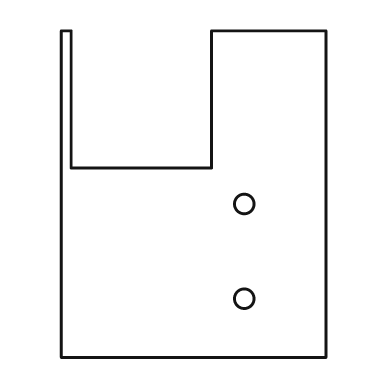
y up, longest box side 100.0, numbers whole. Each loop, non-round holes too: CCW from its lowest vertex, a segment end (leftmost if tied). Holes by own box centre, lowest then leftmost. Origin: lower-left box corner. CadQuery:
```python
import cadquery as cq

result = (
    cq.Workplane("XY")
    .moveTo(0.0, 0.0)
    .lineTo(81.0, 0.0)
    .lineTo(81.0, 100.0)
    .lineTo(46.0, 100.0)
    .lineTo(46.0, 58.0)
    .lineTo(3.0, 58.0)
    .lineTo(3.0, 100.0)
    .lineTo(0.0, 100.0)
    .close()
    .moveTo(56.0, 18.0)
    .circle(3.0)
    .moveTo(56.0, 47.0)
    .circle(3.0)
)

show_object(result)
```